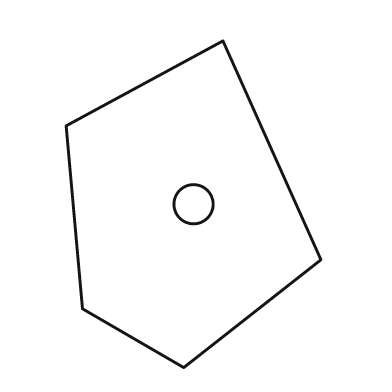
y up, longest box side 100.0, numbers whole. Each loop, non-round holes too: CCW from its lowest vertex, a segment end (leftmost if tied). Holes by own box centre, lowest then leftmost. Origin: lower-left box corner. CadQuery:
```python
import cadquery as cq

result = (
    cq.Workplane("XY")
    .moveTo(36.0, 0.0)
    .lineTo(78.0, 33.0)
    .lineTo(48.0, 100.0)
    .lineTo(0.0, 74.0)
    .lineTo(5.0, 18.0)
    .close()
    .moveTo(39.0, 50.0)
    .circle(6.0)
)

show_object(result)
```